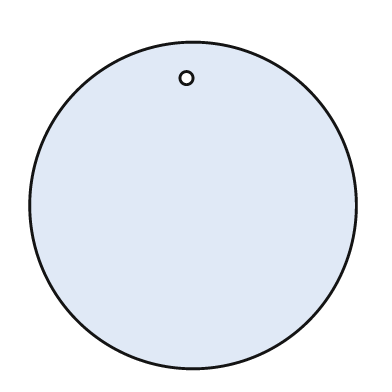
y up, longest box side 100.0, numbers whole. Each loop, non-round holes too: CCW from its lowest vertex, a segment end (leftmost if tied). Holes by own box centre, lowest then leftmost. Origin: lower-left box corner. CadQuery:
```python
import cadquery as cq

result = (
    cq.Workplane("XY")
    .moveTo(50.0, 50.0)
    .circle(50.0)
    .moveTo(48.0, 89.0)
    .circle(2.0)
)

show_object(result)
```